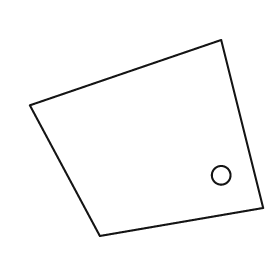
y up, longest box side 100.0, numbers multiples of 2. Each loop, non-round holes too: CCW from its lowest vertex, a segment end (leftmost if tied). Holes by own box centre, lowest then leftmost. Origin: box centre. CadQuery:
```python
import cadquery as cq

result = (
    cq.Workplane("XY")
    .moveTo(-20.0, -42.0)
    .lineTo(50.0, -30.0)
    .lineTo(32.0, 42.0)
    .lineTo(-50.0, 14.0)
    .close()
    .moveTo(32.0, -16.0)
    .circle(4.0)
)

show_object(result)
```